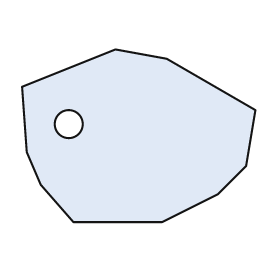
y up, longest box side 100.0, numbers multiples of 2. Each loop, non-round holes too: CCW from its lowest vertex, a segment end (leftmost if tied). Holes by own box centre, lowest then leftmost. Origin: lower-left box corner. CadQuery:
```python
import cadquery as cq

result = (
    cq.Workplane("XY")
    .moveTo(22.0, 0.0)
    .lineTo(60.0, 0.0)
    .lineTo(84.0, 12.0)
    .lineTo(96.0, 24.0)
    .lineTo(100.0, 48.0)
    .lineTo(62.0, 70.0)
    .lineTo(40.0, 74.0)
    .lineTo(0.0, 58.0)
    .lineTo(2.0, 30.0)
    .lineTo(8.0, 16.0)
    .close()
    .moveTo(20.0, 42.0)
    .circle(6.0)
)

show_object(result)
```